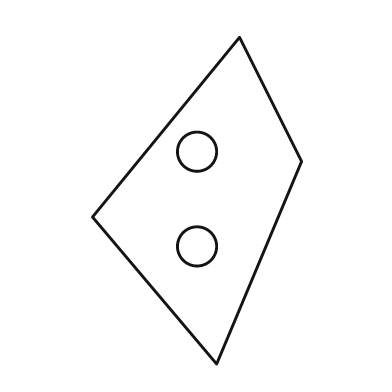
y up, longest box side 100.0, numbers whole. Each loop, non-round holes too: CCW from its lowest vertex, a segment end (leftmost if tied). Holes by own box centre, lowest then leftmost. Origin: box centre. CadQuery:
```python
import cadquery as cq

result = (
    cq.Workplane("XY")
    .moveTo(6.0, -50.0)
    .lineTo(32.0, 12.0)
    .lineTo(13.0, 50.0)
    .lineTo(-32.0, -5.0)
    .close()
    .moveTo(0.0, -14.0)
    .circle(6.0)
    .moveTo(0.0, 15.0)
    .circle(6.0)
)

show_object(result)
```